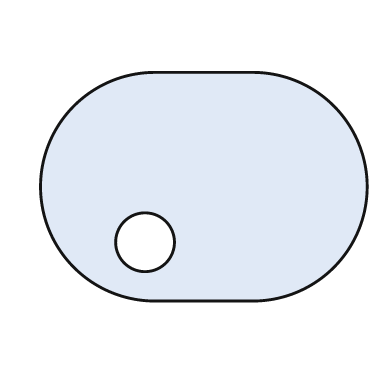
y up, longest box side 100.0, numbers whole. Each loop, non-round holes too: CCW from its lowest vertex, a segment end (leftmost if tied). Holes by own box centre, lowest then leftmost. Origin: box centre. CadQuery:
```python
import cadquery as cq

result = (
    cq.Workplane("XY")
    .moveTo(-15.0, -35.0)
    .lineTo(15.0, -35.0)
    .threePointArc((50.0, 0.0), (15.0, 35.0))
    .lineTo(-15.0, 35.0)
    .threePointArc((-50.0, 0.0), (-15.0, -35.0))
    .close()
    .moveTo(-18.0, -17.0)
    .circle(9.0)
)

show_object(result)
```